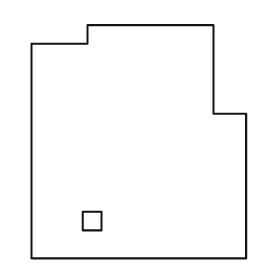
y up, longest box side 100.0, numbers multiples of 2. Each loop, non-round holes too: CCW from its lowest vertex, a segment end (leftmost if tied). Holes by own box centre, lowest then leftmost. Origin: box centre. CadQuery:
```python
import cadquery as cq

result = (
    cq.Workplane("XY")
    .moveTo(-46.0, -50.0)
    .lineTo(46.0, -50.0)
    .lineTo(46.0, 12.0)
    .lineTo(32.0, 12.0)
    .lineTo(32.0, 50.0)
    .lineTo(-22.0, 50.0)
    .lineTo(-22.0, 42.0)
    .lineTo(-46.0, 42.0)
    .close()
    .moveTo(-24.0, -38.0)
    .lineTo(-16.0, -38.0)
    .lineTo(-16.0, -30.0)
    .lineTo(-24.0, -30.0)
    .close()
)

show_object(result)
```